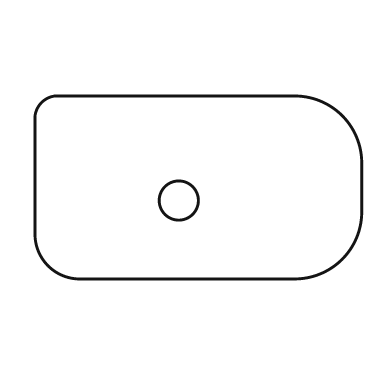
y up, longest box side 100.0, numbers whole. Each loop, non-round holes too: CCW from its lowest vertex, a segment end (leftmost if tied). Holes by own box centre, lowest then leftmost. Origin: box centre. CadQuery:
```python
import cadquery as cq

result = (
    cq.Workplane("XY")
    .moveTo(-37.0, -28.0)
    .lineTo(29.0, -28.0)
    .threePointArc((44.0, -22.0), (50.0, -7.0))
    .lineTo(50.0, 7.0)
    .threePointArc((44.0, 22.0), (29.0, 28.0))
    .lineTo(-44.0, 28.0)
    .threePointArc((-48.0, 26.0), (-50.0, 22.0))
    .lineTo(-50.0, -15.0)
    .threePointArc((-46.0, -24.0), (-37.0, -28.0))
    .close()
    .moveTo(-6.0, -4.0)
    .circle(6.0)
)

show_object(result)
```